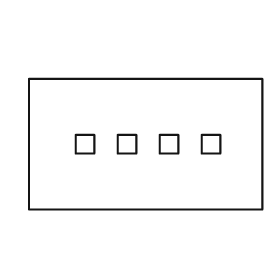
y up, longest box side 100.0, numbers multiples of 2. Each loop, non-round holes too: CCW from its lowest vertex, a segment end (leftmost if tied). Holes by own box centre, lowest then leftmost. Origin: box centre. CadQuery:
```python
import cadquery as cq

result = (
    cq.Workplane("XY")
    .moveTo(-50.0, -28.0)
    .lineTo(50.0, -28.0)
    .lineTo(50.0, 28.0)
    .lineTo(-50.0, 28.0)
    .close()
    .moveTo(-30.0, -4.0)
    .lineTo(-22.0, -4.0)
    .lineTo(-22.0, 4.0)
    .lineTo(-30.0, 4.0)
    .close()
    .moveTo(-12.0, -4.0)
    .lineTo(-4.0, -4.0)
    .lineTo(-4.0, 4.0)
    .lineTo(-12.0, 4.0)
    .close()
    .moveTo(6.0, -4.0)
    .lineTo(14.0, -4.0)
    .lineTo(14.0, 4.0)
    .lineTo(6.0, 4.0)
    .close()
    .moveTo(24.0, -4.0)
    .lineTo(32.0, -4.0)
    .lineTo(32.0, 4.0)
    .lineTo(24.0, 4.0)
    .close()
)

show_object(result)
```